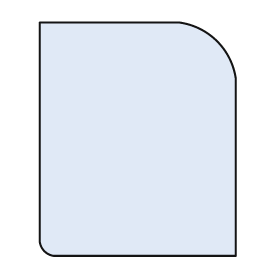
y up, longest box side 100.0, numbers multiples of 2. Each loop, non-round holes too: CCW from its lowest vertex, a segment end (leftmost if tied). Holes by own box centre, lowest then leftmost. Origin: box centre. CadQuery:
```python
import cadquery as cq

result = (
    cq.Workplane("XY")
    .moveTo(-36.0, -50.0)
    .lineTo(42.0, -50.0)
    .lineTo(42.0, 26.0)
    .threePointArc((34.0, 42.0), (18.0, 50.0))
    .lineTo(-42.0, 50.0)
    .lineTo(-42.0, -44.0)
    .threePointArc((-40.0, -48.0), (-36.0, -50.0))
    .close()
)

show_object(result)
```